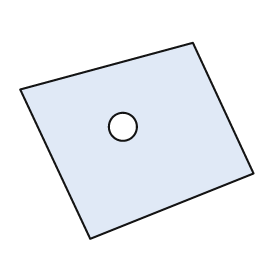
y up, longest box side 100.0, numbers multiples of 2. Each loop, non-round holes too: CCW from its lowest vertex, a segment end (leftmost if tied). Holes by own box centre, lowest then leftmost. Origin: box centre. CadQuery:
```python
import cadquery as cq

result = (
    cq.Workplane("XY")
    .moveTo(-20.0, -42.0)
    .lineTo(50.0, -14.0)
    .lineTo(24.0, 42.0)
    .lineTo(-50.0, 22.0)
    .close()
    .moveTo(-6.0, 6.0)
    .circle(6.0)
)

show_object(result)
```